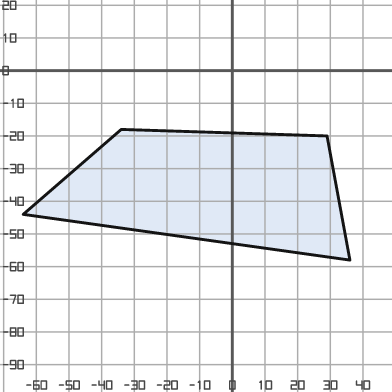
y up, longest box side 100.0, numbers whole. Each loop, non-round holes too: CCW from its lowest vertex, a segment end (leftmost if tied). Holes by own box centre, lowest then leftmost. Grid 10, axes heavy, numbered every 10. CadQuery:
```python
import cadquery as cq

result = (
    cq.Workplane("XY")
    .moveTo(36.0, -58.0)
    .lineTo(29.0, -20.0)
    .lineTo(-34.0, -18.0)
    .lineTo(-64.0, -44.0)
    .close()
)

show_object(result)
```